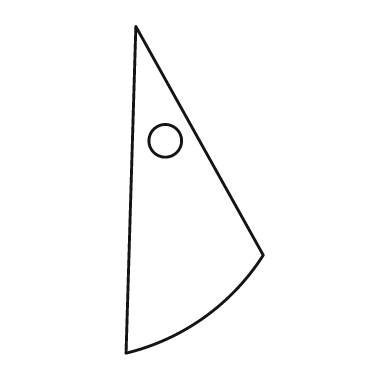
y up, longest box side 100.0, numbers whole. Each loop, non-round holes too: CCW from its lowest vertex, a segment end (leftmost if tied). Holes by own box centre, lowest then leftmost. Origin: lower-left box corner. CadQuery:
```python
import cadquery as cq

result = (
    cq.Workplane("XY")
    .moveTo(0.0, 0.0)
    .threePointArc((24.0, 11.0), (42.0, 30.0))
    .lineTo(3.0, 100.0)
    .close()
    .moveTo(12.0, 65.0)
    .circle(5.0)
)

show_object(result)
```